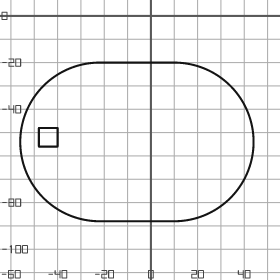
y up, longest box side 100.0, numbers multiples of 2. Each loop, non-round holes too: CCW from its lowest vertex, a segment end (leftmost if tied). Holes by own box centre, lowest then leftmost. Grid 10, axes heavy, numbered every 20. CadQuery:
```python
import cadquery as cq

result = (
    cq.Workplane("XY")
    .moveTo(-22.0, -88.0)
    .lineTo(10.0, -88.0)
    .threePointArc((44.0, -54.0), (10.0, -20.0))
    .lineTo(-22.0, -20.0)
    .threePointArc((-56.0, -54.0), (-22.0, -88.0))
    .close()
    .moveTo(-48.0, -56.0)
    .lineTo(-40.0, -56.0)
    .lineTo(-40.0, -48.0)
    .lineTo(-48.0, -48.0)
    .close()
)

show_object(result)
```